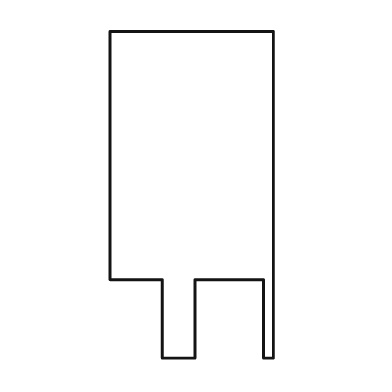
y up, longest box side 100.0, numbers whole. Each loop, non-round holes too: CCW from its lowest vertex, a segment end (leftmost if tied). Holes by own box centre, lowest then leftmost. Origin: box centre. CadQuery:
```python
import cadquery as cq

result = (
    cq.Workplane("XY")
    .moveTo(-9.0, -50.0)
    .lineTo(1.0, -50.0)
    .lineTo(1.0, -26.0)
    .lineTo(22.0, -26.0)
    .lineTo(22.0, -50.0)
    .lineTo(25.0, -50.0)
    .lineTo(25.0, 50.0)
    .lineTo(-25.0, 50.0)
    .lineTo(-25.0, -26.0)
    .lineTo(-9.0, -26.0)
    .close()
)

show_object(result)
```